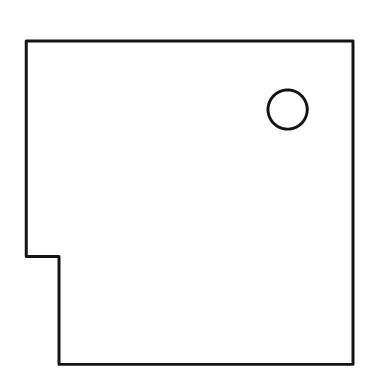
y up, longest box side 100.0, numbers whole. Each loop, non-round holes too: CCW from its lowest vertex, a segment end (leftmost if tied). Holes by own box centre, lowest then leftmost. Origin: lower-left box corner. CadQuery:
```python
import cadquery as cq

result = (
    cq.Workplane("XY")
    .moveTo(10.0, 0.0)
    .lineTo(100.0, 0.0)
    .lineTo(100.0, 99.0)
    .lineTo(0.0, 99.0)
    .lineTo(0.0, 33.0)
    .lineTo(10.0, 33.0)
    .close()
    .moveTo(80.0, 78.0)
    .circle(6.0)
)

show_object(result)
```